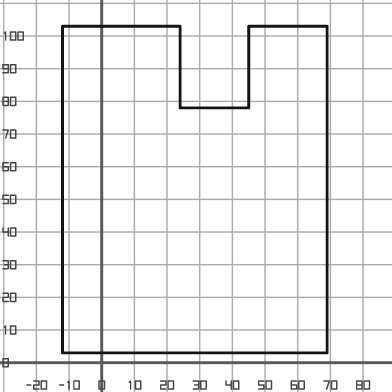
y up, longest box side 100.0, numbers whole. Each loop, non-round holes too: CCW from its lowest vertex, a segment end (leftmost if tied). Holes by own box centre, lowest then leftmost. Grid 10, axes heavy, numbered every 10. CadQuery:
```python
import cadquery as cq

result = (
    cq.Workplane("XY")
    .moveTo(-12.0, 3.0)
    .lineTo(69.0, 3.0)
    .lineTo(69.0, 103.0)
    .lineTo(45.0, 103.0)
    .lineTo(45.0, 78.0)
    .lineTo(24.0, 78.0)
    .lineTo(24.0, 103.0)
    .lineTo(-12.0, 103.0)
    .close()
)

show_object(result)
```